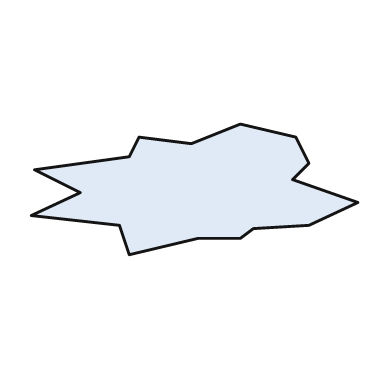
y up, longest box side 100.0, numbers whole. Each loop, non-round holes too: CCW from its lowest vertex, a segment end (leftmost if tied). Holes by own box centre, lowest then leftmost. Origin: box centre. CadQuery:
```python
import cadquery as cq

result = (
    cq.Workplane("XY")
    .moveTo(-20.0, -20.0)
    .lineTo(1.0, -15.0)
    .lineTo(14.0, -15.0)
    .lineTo(18.0, -12.0)
    .lineTo(35.0, -11.0)
    .lineTo(50.0, -4.0)
    .lineTo(30.0, 3.0)
    .lineTo(35.0, 8.0)
    .lineTo(31.0, 16.0)
    .lineTo(14.0, 20.0)
    .lineTo(-1.0, 14.0)
    .lineTo(-17.0, 16.0)
    .lineTo(-20.0, 10.0)
    .lineTo(-49.0, 6.0)
    .lineTo(-35.0, -1.0)
    .lineTo(-50.0, -8.0)
    .lineTo(-23.0, -11.0)
    .close()
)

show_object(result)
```